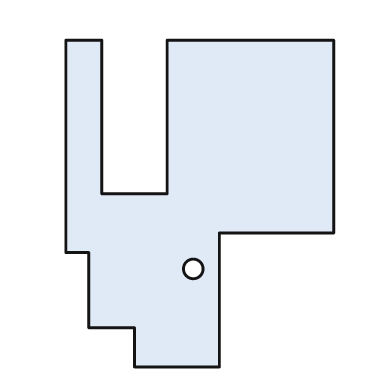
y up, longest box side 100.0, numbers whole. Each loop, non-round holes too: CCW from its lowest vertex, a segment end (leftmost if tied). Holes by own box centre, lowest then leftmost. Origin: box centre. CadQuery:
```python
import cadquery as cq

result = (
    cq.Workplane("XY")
    .moveTo(-20.0, -50.0)
    .lineTo(6.0, -50.0)
    .lineTo(6.0, -9.0)
    .lineTo(41.0, -9.0)
    .lineTo(41.0, 50.0)
    .lineTo(-10.0, 50.0)
    .lineTo(-10.0, 3.0)
    .lineTo(-30.0, 3.0)
    .lineTo(-30.0, 50.0)
    .lineTo(-41.0, 50.0)
    .lineTo(-41.0, -15.0)
    .lineTo(-34.0, -15.0)
    .lineTo(-34.0, -38.0)
    .lineTo(-20.0, -38.0)
    .close()
    .moveTo(-2.0, -20.0)
    .circle(3.0)
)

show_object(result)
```